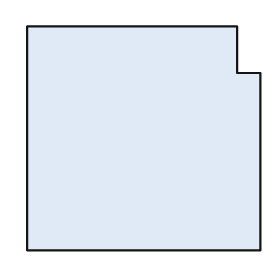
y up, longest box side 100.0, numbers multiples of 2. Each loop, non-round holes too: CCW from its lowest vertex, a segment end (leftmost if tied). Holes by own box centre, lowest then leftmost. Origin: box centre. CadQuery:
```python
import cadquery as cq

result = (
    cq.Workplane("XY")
    .moveTo(-50.0, -48.0)
    .lineTo(50.0, -48.0)
    .lineTo(50.0, 28.0)
    .lineTo(40.0, 28.0)
    .lineTo(40.0, 48.0)
    .lineTo(-50.0, 48.0)
    .close()
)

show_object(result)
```